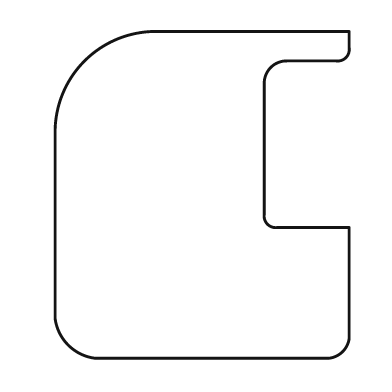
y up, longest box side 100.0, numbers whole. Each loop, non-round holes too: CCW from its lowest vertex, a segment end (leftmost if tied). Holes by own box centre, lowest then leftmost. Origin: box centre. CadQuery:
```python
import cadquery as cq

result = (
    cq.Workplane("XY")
    .moveTo(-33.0, -50.0)
    .lineTo(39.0, -50.0)
    .threePointArc((43.0, -48.0), (45.0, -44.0))
    .lineTo(45.0, -10.0)
    .lineTo(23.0, -10.0)
    .threePointArc((20.0, -9.0), (19.0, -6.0))
    .lineTo(19.0, 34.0)
    .threePointArc((21.0, 39.0), (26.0, 41.0))
    .lineTo(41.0, 41.0)
    .threePointArc((44.0, 42.0), (45.0, 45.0))
    .lineTo(45.0, 50.0)
    .lineTo(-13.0, 50.0)
    .threePointArc((-36.0, 41.0), (-45.0, 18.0))
    .lineTo(-45.0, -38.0)
    .threePointArc((-41.0, -46.0), (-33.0, -50.0))
    .close()
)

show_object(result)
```